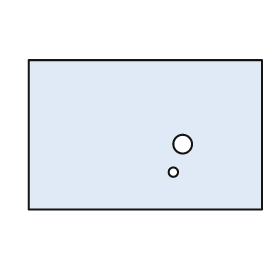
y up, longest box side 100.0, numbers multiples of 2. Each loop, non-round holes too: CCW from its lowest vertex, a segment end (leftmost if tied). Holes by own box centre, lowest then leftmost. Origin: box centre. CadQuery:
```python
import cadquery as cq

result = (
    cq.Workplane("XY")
    .moveTo(-50.0, -32.0)
    .lineTo(50.0, -32.0)
    .lineTo(50.0, 32.0)
    .lineTo(-50.0, 32.0)
    .close()
    .moveTo(12.0, -16.0)
    .circle(2.0)
    .moveTo(16.0, -4.0)
    .circle(4.0)
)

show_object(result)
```